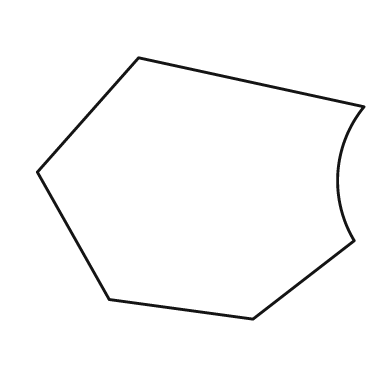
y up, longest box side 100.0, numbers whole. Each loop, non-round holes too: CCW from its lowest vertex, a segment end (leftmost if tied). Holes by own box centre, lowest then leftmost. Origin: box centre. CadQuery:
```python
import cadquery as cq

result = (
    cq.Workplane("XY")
    .moveTo(16.0, -40.0)
    .lineTo(47.0, -16.0)
    .threePointArc((42.0, 5.0), (50.0, 25.0))
    .lineTo(-19.0, 40.0)
    .lineTo(-50.0, 5.0)
    .lineTo(-28.0, -34.0)
    .close()
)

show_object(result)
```